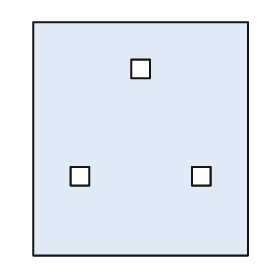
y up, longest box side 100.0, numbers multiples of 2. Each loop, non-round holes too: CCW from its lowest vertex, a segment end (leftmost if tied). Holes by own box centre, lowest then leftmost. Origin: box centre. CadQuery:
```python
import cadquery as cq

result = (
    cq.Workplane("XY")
    .moveTo(-46.0, -50.0)
    .lineTo(46.0, -50.0)
    .lineTo(46.0, 50.0)
    .lineTo(-46.0, 50.0)
    .close()
    .moveTo(-30.0, -20.0)
    .lineTo(-22.0, -20.0)
    .lineTo(-22.0, -12.0)
    .lineTo(-30.0, -12.0)
    .close()
    .moveTo(22.0, -20.0)
    .lineTo(30.0, -20.0)
    .lineTo(30.0, -12.0)
    .lineTo(22.0, -12.0)
    .close()
    .moveTo(-4.0, 26.0)
    .lineTo(4.0, 26.0)
    .lineTo(4.0, 34.0)
    .lineTo(-4.0, 34.0)
    .close()
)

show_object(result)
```